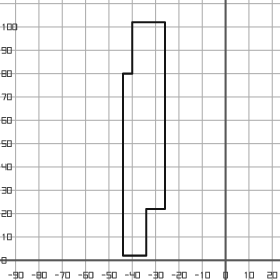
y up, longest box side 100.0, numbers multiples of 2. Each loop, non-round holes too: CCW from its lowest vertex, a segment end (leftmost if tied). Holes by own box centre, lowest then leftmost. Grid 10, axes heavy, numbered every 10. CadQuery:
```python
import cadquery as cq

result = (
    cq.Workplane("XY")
    .moveTo(-44.0, 2.0)
    .lineTo(-34.0, 2.0)
    .lineTo(-34.0, 22.0)
    .lineTo(-26.0, 22.0)
    .lineTo(-26.0, 102.0)
    .lineTo(-40.0, 102.0)
    .lineTo(-40.0, 80.0)
    .lineTo(-44.0, 80.0)
    .close()
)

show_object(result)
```